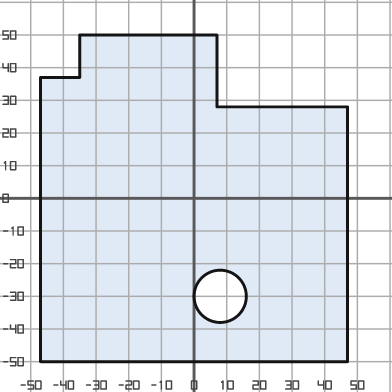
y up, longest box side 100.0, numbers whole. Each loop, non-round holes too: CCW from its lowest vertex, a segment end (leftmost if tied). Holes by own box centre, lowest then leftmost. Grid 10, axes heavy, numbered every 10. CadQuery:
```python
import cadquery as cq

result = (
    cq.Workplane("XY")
    .moveTo(-47.0, -50.0)
    .lineTo(47.0, -50.0)
    .lineTo(47.0, 28.0)
    .lineTo(7.0, 28.0)
    .lineTo(7.0, 50.0)
    .lineTo(-35.0, 50.0)
    .lineTo(-35.0, 37.0)
    .lineTo(-47.0, 37.0)
    .close()
    .moveTo(8.0, -30.0)
    .circle(8.0)
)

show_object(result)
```